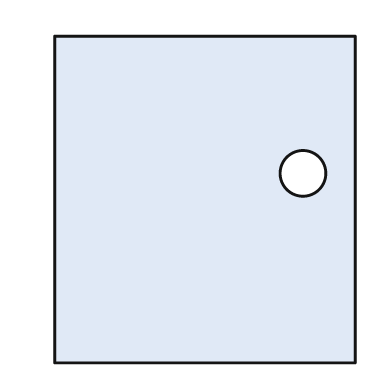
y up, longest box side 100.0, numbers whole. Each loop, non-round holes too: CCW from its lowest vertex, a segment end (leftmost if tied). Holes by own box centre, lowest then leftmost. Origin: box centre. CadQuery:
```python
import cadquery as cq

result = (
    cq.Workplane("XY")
    .moveTo(-46.0, -50.0)
    .lineTo(46.0, -50.0)
    .lineTo(46.0, 50.0)
    .lineTo(-46.0, 50.0)
    .close()
    .moveTo(30.0, 8.0)
    .circle(7.0)
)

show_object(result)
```